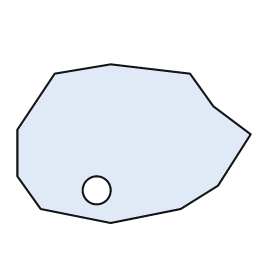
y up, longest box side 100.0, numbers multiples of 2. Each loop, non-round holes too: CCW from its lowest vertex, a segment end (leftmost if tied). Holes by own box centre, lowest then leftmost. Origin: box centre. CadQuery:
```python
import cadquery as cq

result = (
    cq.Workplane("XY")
    .moveTo(-10.0, -34.0)
    .lineTo(20.0, -28.0)
    .lineTo(36.0, -18.0)
    .lineTo(50.0, 4.0)
    .lineTo(34.0, 16.0)
    .lineTo(24.0, 30.0)
    .lineTo(-10.0, 34.0)
    .lineTo(-34.0, 30.0)
    .lineTo(-50.0, 6.0)
    .lineTo(-50.0, -14.0)
    .lineTo(-40.0, -28.0)
    .close()
    .moveTo(-16.0, -20.0)
    .circle(6.0)
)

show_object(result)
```